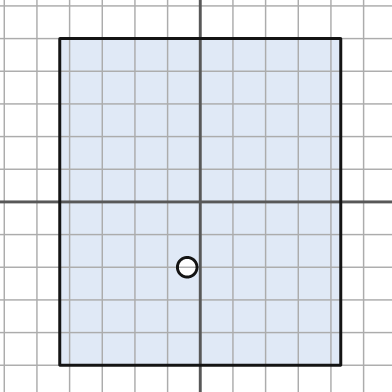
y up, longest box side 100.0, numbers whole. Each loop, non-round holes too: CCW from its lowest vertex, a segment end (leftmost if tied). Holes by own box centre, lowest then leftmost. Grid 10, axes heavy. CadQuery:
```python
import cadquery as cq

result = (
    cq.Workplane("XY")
    .moveTo(-43.0, -50.0)
    .lineTo(43.0, -50.0)
    .lineTo(43.0, 50.0)
    .lineTo(-43.0, 50.0)
    .close()
    .moveTo(-4.0, -20.0)
    .circle(3.0)
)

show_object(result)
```